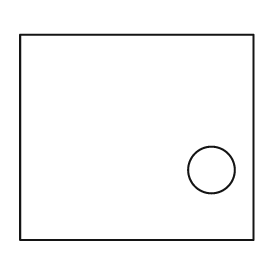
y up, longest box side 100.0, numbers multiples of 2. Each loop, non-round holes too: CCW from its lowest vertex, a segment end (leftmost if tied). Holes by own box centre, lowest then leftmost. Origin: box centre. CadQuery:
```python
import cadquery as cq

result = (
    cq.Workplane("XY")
    .moveTo(-50.0, -44.0)
    .lineTo(50.0, -44.0)
    .lineTo(50.0, 44.0)
    .lineTo(-50.0, 44.0)
    .close()
    .moveTo(32.0, -14.0)
    .circle(10.0)
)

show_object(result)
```